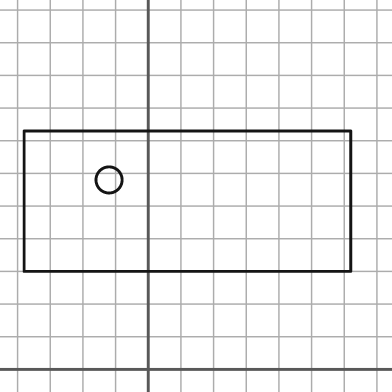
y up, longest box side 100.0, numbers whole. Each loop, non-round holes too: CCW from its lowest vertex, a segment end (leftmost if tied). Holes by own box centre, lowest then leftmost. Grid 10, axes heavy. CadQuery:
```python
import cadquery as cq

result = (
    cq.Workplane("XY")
    .moveTo(-38.0, 30.0)
    .lineTo(62.0, 30.0)
    .lineTo(62.0, 73.0)
    .lineTo(-38.0, 73.0)
    .close()
    .moveTo(-12.0, 58.0)
    .circle(4.0)
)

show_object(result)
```